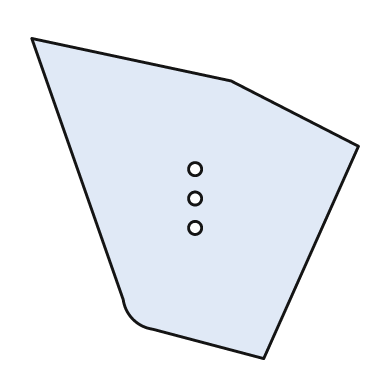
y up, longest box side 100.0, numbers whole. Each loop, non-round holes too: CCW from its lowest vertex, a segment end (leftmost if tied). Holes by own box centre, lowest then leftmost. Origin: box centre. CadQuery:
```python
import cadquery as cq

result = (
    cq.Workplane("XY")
    .moveTo(21.0, -49.0)
    .lineTo(50.0, 16.0)
    .lineTo(11.0, 36.0)
    .lineTo(-50.0, 49.0)
    .lineTo(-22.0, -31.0)
    .threePointArc((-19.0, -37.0), (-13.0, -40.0))
    .close()
    .moveTo(0.0, -9.0)
    .circle(2.0)
    .moveTo(0.0, 0.0)
    .circle(2.0)
    .moveTo(0.0, 9.0)
    .circle(2.0)
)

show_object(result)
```